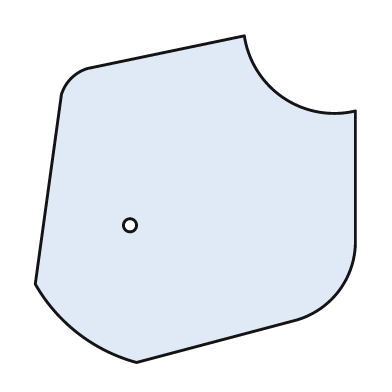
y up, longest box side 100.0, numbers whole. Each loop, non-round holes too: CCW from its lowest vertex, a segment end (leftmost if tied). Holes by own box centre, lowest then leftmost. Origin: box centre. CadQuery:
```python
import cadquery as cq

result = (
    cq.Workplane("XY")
    .moveTo(-18.0, -50.0)
    .lineTo(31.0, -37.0)
    .threePointArc((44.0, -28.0), (49.0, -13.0))
    .lineTo(49.0, 27.0)
    .threePointArc((27.0, 31.0), (15.0, 50.0))
    .lineTo(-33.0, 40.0)
    .threePointArc((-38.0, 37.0), (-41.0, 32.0))
    .lineTo(-49.0, -26.0)
    .threePointArc((-36.0, -41.0), (-18.0, -50.0))
    .close()
    .moveTo(-20.0, -8.0)
    .circle(2.0)
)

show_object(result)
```